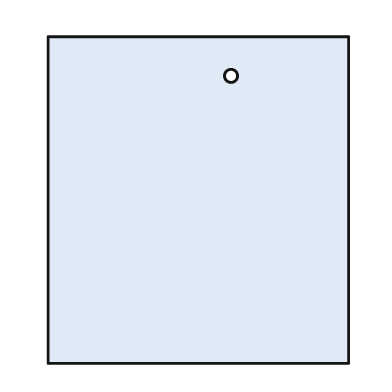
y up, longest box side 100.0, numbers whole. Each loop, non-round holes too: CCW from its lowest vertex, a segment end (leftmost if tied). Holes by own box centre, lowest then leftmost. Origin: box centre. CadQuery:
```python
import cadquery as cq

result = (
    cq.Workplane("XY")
    .moveTo(-46.0, -50.0)
    .lineTo(46.0, -50.0)
    .lineTo(46.0, 50.0)
    .lineTo(-46.0, 50.0)
    .close()
    .moveTo(10.0, 38.0)
    .circle(2.0)
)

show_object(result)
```